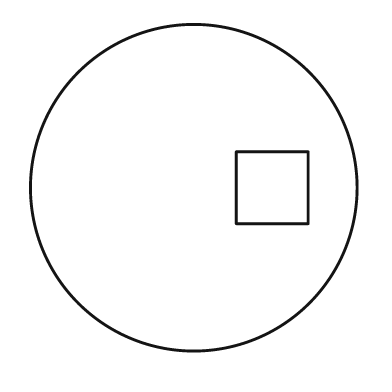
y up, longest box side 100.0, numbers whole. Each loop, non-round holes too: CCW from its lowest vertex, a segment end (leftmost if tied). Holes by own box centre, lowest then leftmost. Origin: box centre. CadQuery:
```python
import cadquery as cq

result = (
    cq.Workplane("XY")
    .moveTo(0.0, 0.0)
    .circle(50.0)
    .moveTo(13.0, -11.0)
    .lineTo(35.0, -11.0)
    .lineTo(35.0, 11.0)
    .lineTo(13.0, 11.0)
    .close()
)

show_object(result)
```